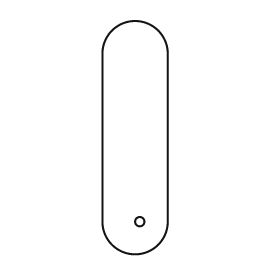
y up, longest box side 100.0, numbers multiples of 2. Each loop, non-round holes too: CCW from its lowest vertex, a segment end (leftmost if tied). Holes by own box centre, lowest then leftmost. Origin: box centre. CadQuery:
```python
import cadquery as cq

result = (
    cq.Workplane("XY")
    .moveTo(-14.0, -36.0)
    .threePointArc((0.0, -50.0), (14.0, -36.0))
    .lineTo(14.0, 36.0)
    .threePointArc((0.0, 50.0), (-14.0, 36.0))
    .close()
    .moveTo(2.0, -36.0)
    .circle(2.0)
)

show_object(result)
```